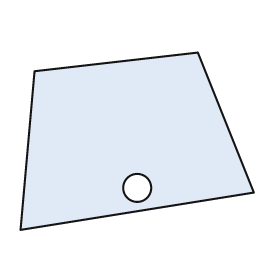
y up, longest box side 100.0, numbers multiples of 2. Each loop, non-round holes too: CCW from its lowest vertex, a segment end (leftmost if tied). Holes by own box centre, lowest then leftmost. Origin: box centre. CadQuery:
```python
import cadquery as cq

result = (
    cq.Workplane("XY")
    .moveTo(-50.0, -38.0)
    .lineTo(50.0, -22.0)
    .lineTo(26.0, 38.0)
    .lineTo(-44.0, 30.0)
    .close()
    .moveTo(0.0, -20.0)
    .circle(6.0)
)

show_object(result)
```